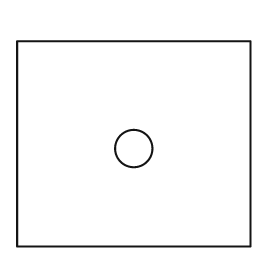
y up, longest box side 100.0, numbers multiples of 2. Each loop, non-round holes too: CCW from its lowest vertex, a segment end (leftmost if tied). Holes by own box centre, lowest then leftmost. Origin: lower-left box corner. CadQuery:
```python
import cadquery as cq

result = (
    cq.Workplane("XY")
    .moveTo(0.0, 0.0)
    .lineTo(100.0, 0.0)
    .lineTo(100.0, 88.0)
    .lineTo(0.0, 88.0)
    .close()
    .moveTo(50.0, 42.0)
    .circle(8.0)
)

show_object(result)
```